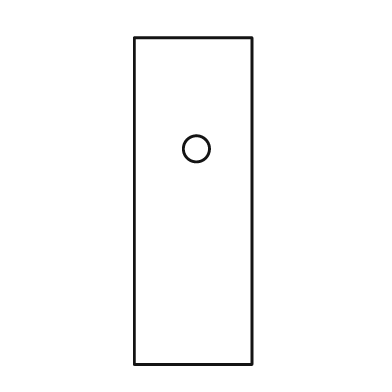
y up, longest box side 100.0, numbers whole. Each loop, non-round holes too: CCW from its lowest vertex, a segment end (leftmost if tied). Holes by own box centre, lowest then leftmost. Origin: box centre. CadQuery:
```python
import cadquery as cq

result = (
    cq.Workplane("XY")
    .moveTo(-18.0, -50.0)
    .lineTo(18.0, -50.0)
    .lineTo(18.0, 50.0)
    .lineTo(-18.0, 50.0)
    .close()
    .moveTo(1.0, 16.0)
    .circle(4.0)
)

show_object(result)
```